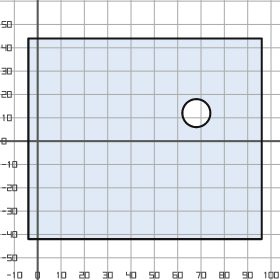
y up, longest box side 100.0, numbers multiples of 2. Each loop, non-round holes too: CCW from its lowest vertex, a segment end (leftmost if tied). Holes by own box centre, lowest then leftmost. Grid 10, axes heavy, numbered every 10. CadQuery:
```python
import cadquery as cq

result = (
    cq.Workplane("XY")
    .moveTo(-4.0, -42.0)
    .lineTo(96.0, -42.0)
    .lineTo(96.0, 44.0)
    .lineTo(-4.0, 44.0)
    .close()
    .moveTo(68.0, 12.0)
    .circle(6.0)
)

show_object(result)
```